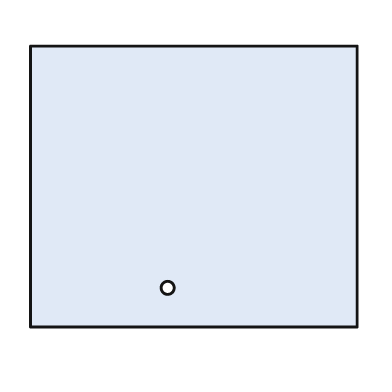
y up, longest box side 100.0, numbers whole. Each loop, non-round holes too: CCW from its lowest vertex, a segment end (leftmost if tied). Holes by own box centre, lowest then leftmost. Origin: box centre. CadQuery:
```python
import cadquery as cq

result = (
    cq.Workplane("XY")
    .moveTo(-50.0, -43.0)
    .lineTo(50.0, -43.0)
    .lineTo(50.0, 43.0)
    .lineTo(-50.0, 43.0)
    .close()
    .moveTo(-8.0, -31.0)
    .circle(2.0)
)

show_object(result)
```